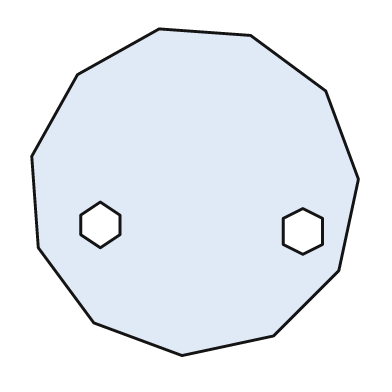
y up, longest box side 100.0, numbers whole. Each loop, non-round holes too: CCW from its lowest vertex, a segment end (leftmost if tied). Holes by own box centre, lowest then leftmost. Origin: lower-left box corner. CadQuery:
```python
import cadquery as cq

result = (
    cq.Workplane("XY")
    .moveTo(46.0, 0.0)
    .lineTo(74.0, 6.0)
    .lineTo(94.0, 26.0)
    .lineTo(100.0, 54.0)
    .lineTo(90.0, 81.0)
    .lineTo(67.0, 98.0)
    .lineTo(39.0, 100.0)
    .lineTo(14.0, 86.0)
    .lineTo(0.0, 61.0)
    .lineTo(2.0, 33.0)
    .lineTo(19.0, 10.0)
    .close()
    .moveTo(83.0, 31.0)
    .lineTo(89.0, 34.0)
    .lineTo(89.0, 42.0)
    .lineTo(83.0, 45.0)
    .lineTo(77.0, 42.0)
    .lineTo(77.0, 34.0)
    .close()
    .moveTo(21.0, 33.0)
    .lineTo(27.0, 37.0)
    .lineTo(27.0, 43.0)
    .lineTo(21.0, 47.0)
    .lineTo(15.0, 43.0)
    .lineTo(15.0, 37.0)
    .close()
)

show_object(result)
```